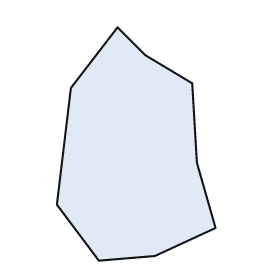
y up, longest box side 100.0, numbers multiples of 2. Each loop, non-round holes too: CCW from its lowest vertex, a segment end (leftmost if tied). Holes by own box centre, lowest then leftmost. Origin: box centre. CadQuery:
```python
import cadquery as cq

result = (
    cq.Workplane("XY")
    .moveTo(-16.0, -50.0)
    .lineTo(8.0, -48.0)
    .lineTo(34.0, -36.0)
    .lineTo(26.0, -8.0)
    .lineTo(24.0, 26.0)
    .lineTo(4.0, 38.0)
    .lineTo(-8.0, 50.0)
    .lineTo(-28.0, 24.0)
    .lineTo(-34.0, -26.0)
    .close()
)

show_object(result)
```